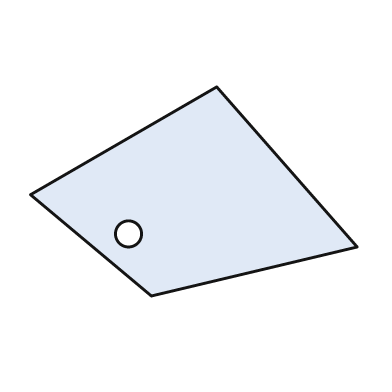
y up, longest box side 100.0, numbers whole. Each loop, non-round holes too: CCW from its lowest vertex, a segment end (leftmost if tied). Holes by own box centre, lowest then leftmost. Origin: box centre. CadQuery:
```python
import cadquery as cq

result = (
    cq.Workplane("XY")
    .moveTo(-13.0, -32.0)
    .lineTo(50.0, -17.0)
    .lineTo(7.0, 32.0)
    .lineTo(-50.0, -1.0)
    .close()
    .moveTo(-20.0, -13.0)
    .circle(4.0)
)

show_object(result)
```